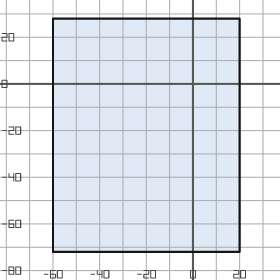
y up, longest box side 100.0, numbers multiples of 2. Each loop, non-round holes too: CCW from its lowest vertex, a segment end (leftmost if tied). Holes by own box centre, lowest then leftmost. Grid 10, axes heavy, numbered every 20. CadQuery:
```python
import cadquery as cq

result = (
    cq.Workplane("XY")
    .moveTo(-60.0, -72.0)
    .lineTo(20.0, -72.0)
    .lineTo(20.0, 28.0)
    .lineTo(-60.0, 28.0)
    .close()
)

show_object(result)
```